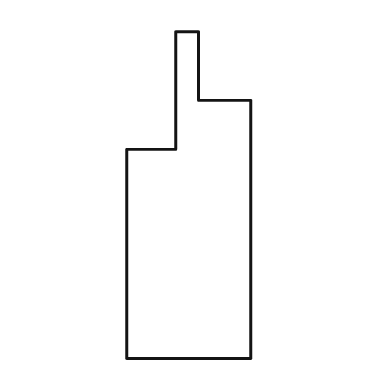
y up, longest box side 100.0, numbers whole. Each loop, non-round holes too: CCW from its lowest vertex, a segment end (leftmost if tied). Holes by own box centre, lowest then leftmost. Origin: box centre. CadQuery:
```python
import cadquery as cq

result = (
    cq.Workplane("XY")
    .moveTo(-19.0, -50.0)
    .lineTo(19.0, -50.0)
    .lineTo(19.0, 29.0)
    .lineTo(3.0, 29.0)
    .lineTo(3.0, 50.0)
    .lineTo(-4.0, 50.0)
    .lineTo(-4.0, 14.0)
    .lineTo(-19.0, 14.0)
    .close()
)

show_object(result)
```